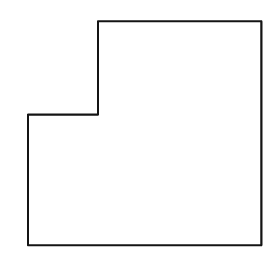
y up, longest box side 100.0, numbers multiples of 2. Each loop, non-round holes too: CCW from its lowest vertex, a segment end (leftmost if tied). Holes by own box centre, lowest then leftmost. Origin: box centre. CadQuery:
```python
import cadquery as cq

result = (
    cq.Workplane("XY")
    .moveTo(-50.0, -48.0)
    .lineTo(50.0, -48.0)
    .lineTo(50.0, 48.0)
    .lineTo(-20.0, 48.0)
    .lineTo(-20.0, 8.0)
    .lineTo(-50.0, 8.0)
    .close()
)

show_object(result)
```